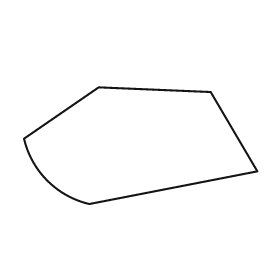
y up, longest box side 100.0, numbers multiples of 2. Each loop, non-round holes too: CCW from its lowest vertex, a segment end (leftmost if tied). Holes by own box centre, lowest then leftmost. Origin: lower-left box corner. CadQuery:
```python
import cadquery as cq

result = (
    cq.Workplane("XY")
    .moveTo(28.0, 0.0)
    .lineTo(100.0, 14.0)
    .lineTo(80.0, 48.0)
    .lineTo(32.0, 50.0)
    .lineTo(0.0, 28.0)
    .threePointArc((10.0, 10.0), (28.0, 0.0))
    .close()
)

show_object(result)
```